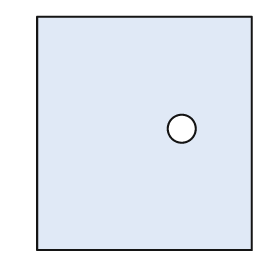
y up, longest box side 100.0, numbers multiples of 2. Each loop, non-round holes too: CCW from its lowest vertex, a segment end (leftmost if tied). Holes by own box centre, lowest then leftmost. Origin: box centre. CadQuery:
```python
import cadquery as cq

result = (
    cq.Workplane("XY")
    .moveTo(-46.0, -50.0)
    .lineTo(46.0, -50.0)
    .lineTo(46.0, 50.0)
    .lineTo(-46.0, 50.0)
    .close()
    .moveTo(16.0, 2.0)
    .circle(6.0)
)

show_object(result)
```